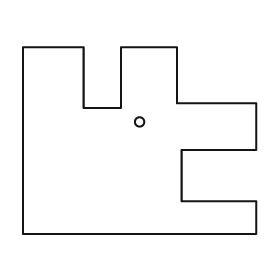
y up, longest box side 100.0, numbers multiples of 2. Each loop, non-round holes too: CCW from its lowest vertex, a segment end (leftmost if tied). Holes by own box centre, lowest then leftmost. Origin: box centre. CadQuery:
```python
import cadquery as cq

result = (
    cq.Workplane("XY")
    .moveTo(-50.0, -40.0)
    .lineTo(50.0, -40.0)
    .lineTo(50.0, -26.0)
    .lineTo(18.0, -26.0)
    .lineTo(18.0, -4.0)
    .lineTo(50.0, -4.0)
    .lineTo(50.0, 16.0)
    .lineTo(16.0, 16.0)
    .lineTo(16.0, 40.0)
    .lineTo(-8.0, 40.0)
    .lineTo(-8.0, 14.0)
    .lineTo(-24.0, 14.0)
    .lineTo(-24.0, 40.0)
    .lineTo(-50.0, 40.0)
    .close()
    .moveTo(0.0, 8.0)
    .circle(2.0)
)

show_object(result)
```